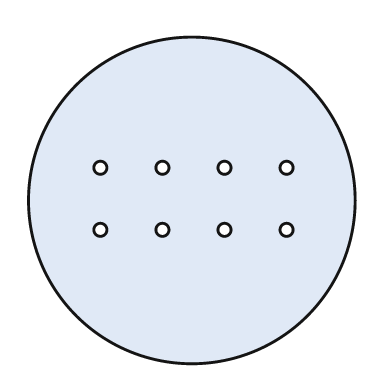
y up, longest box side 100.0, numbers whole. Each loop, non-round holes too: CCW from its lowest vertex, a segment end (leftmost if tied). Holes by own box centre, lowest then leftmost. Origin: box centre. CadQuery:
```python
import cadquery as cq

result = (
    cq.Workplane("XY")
    .moveTo(0.0, 0.0)
    .circle(50.0)
    .moveTo(-28.0, -9.0)
    .circle(2.0)
    .moveTo(-9.0, -9.0)
    .circle(2.0)
    .moveTo(10.0, -9.0)
    .circle(2.0)
    .moveTo(29.0, -9.0)
    .circle(2.0)
    .moveTo(-28.0, 10.0)
    .circle(2.0)
    .moveTo(-9.0, 10.0)
    .circle(2.0)
    .moveTo(10.0, 10.0)
    .circle(2.0)
    .moveTo(29.0, 10.0)
    .circle(2.0)
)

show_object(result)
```